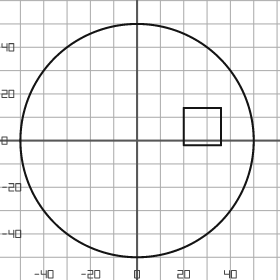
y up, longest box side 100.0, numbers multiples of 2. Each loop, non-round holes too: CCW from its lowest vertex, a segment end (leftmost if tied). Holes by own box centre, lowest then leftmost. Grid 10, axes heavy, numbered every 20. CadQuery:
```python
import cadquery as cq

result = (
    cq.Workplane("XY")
    .moveTo(0.0, 0.0)
    .circle(50.0)
    .moveTo(20.0, -2.0)
    .lineTo(36.0, -2.0)
    .lineTo(36.0, 14.0)
    .lineTo(20.0, 14.0)
    .close()
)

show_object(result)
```